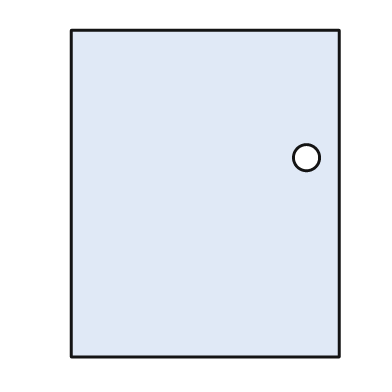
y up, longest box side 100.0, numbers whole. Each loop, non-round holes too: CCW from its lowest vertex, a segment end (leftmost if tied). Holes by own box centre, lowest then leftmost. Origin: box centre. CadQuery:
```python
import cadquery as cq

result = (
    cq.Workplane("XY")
    .moveTo(-41.0, -50.0)
    .lineTo(41.0, -50.0)
    .lineTo(41.0, 50.0)
    .lineTo(-41.0, 50.0)
    .close()
    .moveTo(31.0, 11.0)
    .circle(4.0)
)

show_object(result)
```